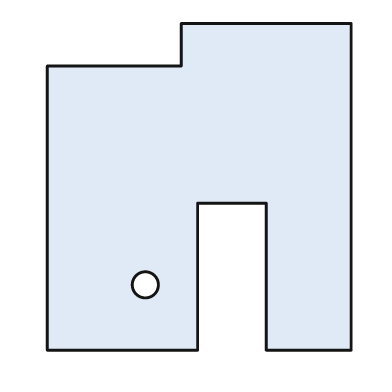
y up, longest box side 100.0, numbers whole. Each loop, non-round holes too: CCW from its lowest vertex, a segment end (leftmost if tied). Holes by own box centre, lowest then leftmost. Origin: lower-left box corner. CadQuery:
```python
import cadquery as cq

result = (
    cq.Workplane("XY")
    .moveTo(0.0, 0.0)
    .lineTo(46.0, 0.0)
    .lineTo(46.0, 45.0)
    .lineTo(67.0, 45.0)
    .lineTo(67.0, 0.0)
    .lineTo(93.0, 0.0)
    .lineTo(93.0, 100.0)
    .lineTo(41.0, 100.0)
    .lineTo(41.0, 87.0)
    .lineTo(0.0, 87.0)
    .close()
    .moveTo(30.0, 20.0)
    .circle(4.0)
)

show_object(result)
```